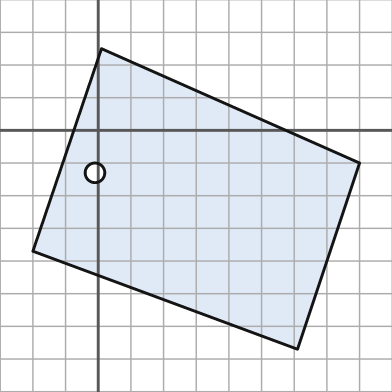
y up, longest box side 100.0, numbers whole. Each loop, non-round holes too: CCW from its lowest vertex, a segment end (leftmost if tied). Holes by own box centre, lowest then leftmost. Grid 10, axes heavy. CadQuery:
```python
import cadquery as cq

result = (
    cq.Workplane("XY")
    .moveTo(61.0, -67.0)
    .lineTo(80.0, -10.0)
    .lineTo(1.0, 25.0)
    .lineTo(-20.0, -37.0)
    .close()
    .moveTo(-1.0, -13.0)
    .circle(3.0)
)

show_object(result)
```